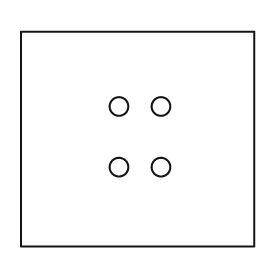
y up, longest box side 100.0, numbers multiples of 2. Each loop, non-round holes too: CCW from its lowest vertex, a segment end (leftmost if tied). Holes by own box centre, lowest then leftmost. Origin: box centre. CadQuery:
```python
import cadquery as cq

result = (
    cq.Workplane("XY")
    .moveTo(-50.0, -46.0)
    .lineTo(50.0, -46.0)
    .lineTo(50.0, 46.0)
    .lineTo(-50.0, 46.0)
    .close()
    .moveTo(-8.0, -12.0)
    .circle(4.0)
    .moveTo(10.0, -12.0)
    .circle(4.0)
    .moveTo(-8.0, 14.0)
    .circle(4.0)
    .moveTo(10.0, 14.0)
    .circle(4.0)
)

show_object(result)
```